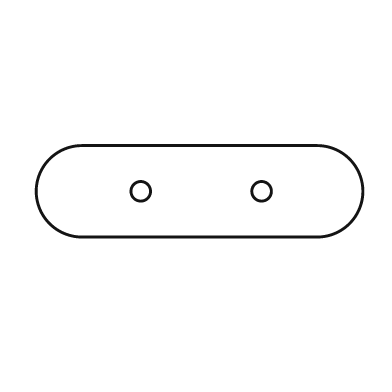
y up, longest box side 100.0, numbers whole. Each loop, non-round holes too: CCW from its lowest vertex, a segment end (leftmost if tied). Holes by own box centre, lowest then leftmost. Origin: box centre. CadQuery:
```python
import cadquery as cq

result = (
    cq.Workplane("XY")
    .moveTo(-36.0, -14.0)
    .lineTo(36.0, -14.0)
    .threePointArc((50.0, 0.0), (36.0, 14.0))
    .lineTo(-36.0, 14.0)
    .threePointArc((-50.0, 0.0), (-36.0, -14.0))
    .close()
    .moveTo(-18.0, 0.0)
    .circle(3.0)
    .moveTo(19.0, 0.0)
    .circle(3.0)
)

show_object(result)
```